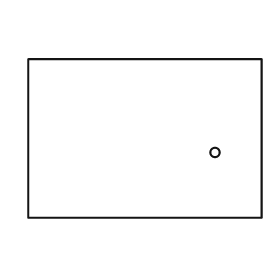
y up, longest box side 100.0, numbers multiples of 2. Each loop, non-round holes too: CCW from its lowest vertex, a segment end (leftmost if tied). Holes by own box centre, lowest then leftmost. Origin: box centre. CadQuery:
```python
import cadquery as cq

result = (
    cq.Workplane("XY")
    .moveTo(-50.0, -34.0)
    .lineTo(50.0, -34.0)
    .lineTo(50.0, 34.0)
    .lineTo(-50.0, 34.0)
    .close()
    .moveTo(30.0, -6.0)
    .circle(2.0)
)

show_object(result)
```